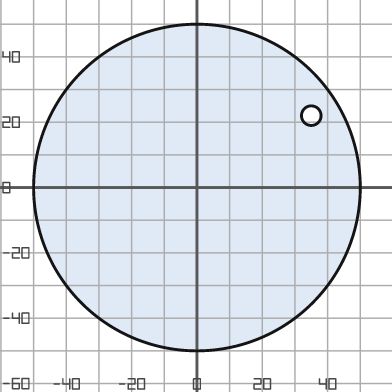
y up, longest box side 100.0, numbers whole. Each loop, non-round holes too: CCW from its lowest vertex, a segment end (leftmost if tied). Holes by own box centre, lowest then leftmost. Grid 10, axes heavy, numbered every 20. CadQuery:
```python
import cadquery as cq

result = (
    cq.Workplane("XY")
    .moveTo(0.0, 0.0)
    .circle(50.0)
    .moveTo(35.0, 22.0)
    .circle(3.0)
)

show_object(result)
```